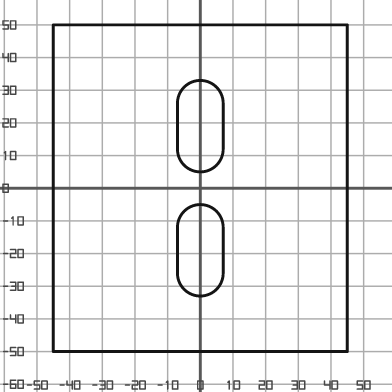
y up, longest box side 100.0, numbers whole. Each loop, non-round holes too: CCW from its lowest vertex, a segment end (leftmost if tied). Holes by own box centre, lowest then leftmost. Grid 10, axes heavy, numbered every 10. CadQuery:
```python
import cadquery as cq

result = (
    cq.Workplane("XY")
    .moveTo(-45.0, -50.0)
    .lineTo(45.0, -50.0)
    .lineTo(45.0, 50.0)
    .lineTo(-45.0, 50.0)
    .close()
    .moveTo(-7.0, -26.0)
    .threePointArc((0.0, -33.0), (7.0, -26.0))
    .lineTo(7.0, -12.0)
    .threePointArc((0.0, -5.0), (-7.0, -12.0))
    .close()
    .moveTo(-7.0, 12.0)
    .threePointArc((0.0, 5.0), (7.0, 12.0))
    .lineTo(7.0, 26.0)
    .threePointArc((0.0, 33.0), (-7.0, 26.0))
    .close()
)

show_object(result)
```